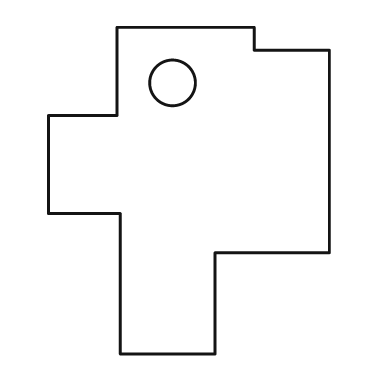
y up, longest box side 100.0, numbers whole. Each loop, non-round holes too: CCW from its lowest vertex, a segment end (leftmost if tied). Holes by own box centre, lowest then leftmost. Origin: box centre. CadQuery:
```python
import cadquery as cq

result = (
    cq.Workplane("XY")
    .moveTo(-21.0, -50.0)
    .lineTo(8.0, -50.0)
    .lineTo(8.0, -19.0)
    .lineTo(43.0, -19.0)
    .lineTo(43.0, 43.0)
    .lineTo(20.0, 43.0)
    .lineTo(20.0, 50.0)
    .lineTo(-22.0, 50.0)
    .lineTo(-22.0, 23.0)
    .lineTo(-43.0, 23.0)
    .lineTo(-43.0, -7.0)
    .lineTo(-21.0, -7.0)
    .close()
    .moveTo(-5.0, 33.0)
    .circle(7.0)
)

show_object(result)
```